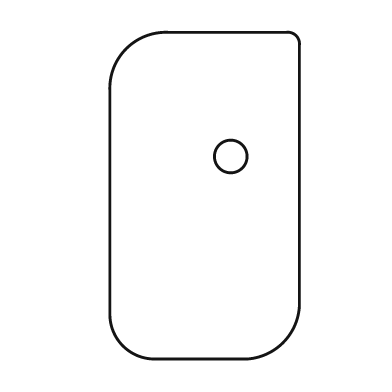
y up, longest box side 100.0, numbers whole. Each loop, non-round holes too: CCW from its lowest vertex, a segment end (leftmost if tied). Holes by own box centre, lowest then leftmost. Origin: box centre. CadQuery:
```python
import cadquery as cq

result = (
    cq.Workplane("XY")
    .moveTo(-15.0, -50.0)
    .lineTo(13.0, -50.0)
    .threePointArc((24.0, -45.0), (29.0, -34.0))
    .lineTo(29.0, 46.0)
    .threePointArc((28.0, 49.0), (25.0, 50.0))
    .lineTo(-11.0, 50.0)
    .threePointArc((-24.0, 45.0), (-29.0, 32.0))
    .lineTo(-29.0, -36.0)
    .threePointArc((-25.0, -46.0), (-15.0, -50.0))
    .close()
    .moveTo(8.0, 12.0)
    .circle(5.0)
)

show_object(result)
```